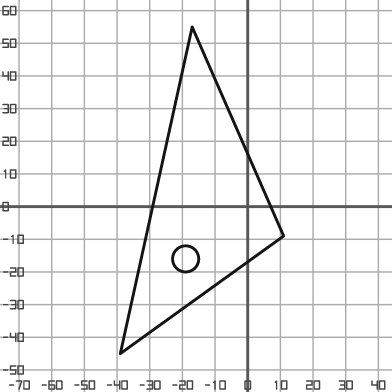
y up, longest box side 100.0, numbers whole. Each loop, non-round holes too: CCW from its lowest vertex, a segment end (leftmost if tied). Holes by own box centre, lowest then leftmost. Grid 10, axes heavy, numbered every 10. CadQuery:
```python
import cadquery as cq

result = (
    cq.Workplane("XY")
    .moveTo(-39.0, -45.0)
    .lineTo(11.0, -9.0)
    .lineTo(-17.0, 55.0)
    .close()
    .moveTo(-19.0, -16.0)
    .circle(4.0)
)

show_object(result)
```